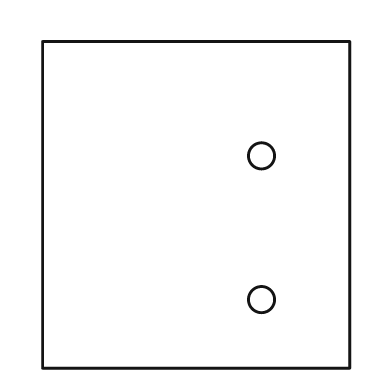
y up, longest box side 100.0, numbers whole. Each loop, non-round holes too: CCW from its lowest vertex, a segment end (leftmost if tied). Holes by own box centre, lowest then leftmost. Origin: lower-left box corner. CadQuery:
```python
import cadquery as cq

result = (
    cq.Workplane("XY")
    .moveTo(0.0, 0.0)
    .lineTo(94.0, 0.0)
    .lineTo(94.0, 100.0)
    .lineTo(0.0, 100.0)
    .close()
    .moveTo(67.0, 21.0)
    .circle(4.0)
    .moveTo(67.0, 65.0)
    .circle(4.0)
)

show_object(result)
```